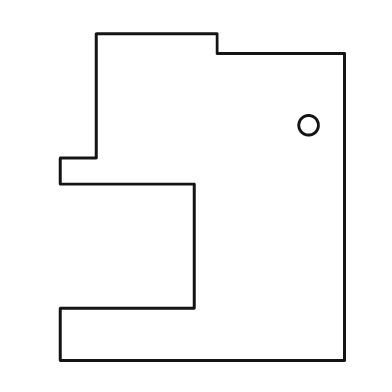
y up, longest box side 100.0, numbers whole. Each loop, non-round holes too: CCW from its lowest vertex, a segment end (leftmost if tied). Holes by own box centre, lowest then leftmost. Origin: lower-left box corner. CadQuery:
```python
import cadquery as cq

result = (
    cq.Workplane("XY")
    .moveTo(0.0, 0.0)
    .lineTo(87.0, 0.0)
    .lineTo(87.0, 94.0)
    .lineTo(48.0, 94.0)
    .lineTo(48.0, 100.0)
    .lineTo(11.0, 100.0)
    .lineTo(11.0, 62.0)
    .lineTo(0.0, 62.0)
    .lineTo(0.0, 54.0)
    .lineTo(41.0, 54.0)
    .lineTo(41.0, 16.0)
    .lineTo(0.0, 16.0)
    .close()
    .moveTo(76.0, 72.0)
    .circle(3.0)
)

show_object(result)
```